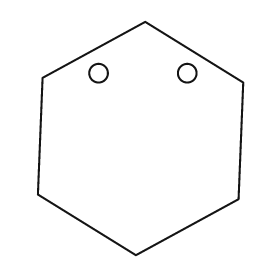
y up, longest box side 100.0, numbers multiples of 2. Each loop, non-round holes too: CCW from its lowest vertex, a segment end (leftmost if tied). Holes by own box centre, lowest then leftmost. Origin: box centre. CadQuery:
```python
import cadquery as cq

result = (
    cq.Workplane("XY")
    .moveTo(-2.0, -50.0)
    .lineTo(42.0, -26.0)
    .lineTo(44.0, 24.0)
    .lineTo(2.0, 50.0)
    .lineTo(-42.0, 26.0)
    .lineTo(-44.0, -24.0)
    .close()
    .moveTo(-18.0, 28.0)
    .circle(4.0)
    .moveTo(20.0, 28.0)
    .circle(4.0)
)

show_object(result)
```